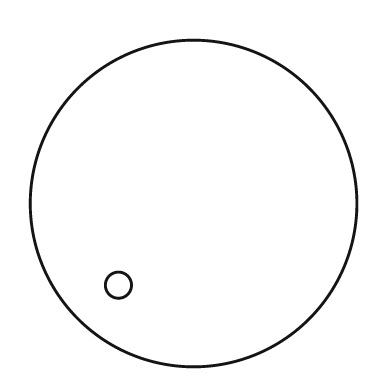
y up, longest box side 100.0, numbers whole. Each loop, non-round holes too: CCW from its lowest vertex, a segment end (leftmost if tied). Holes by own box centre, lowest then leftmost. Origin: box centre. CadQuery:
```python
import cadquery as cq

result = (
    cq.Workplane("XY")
    .moveTo(0.0, 0.0)
    .circle(50.0)
    .moveTo(-23.0, -25.0)
    .circle(4.0)
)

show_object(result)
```